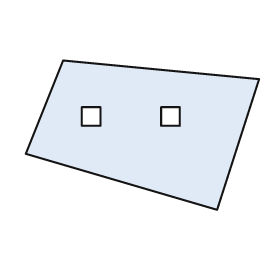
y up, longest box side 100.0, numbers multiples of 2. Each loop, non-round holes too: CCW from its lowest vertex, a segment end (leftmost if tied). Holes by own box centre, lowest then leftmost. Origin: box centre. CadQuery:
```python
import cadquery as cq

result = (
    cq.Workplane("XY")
    .moveTo(32.0, -32.0)
    .lineTo(50.0, 24.0)
    .lineTo(-34.0, 32.0)
    .lineTo(-50.0, -8.0)
    .close()
    .moveTo(-26.0, 4.0)
    .lineTo(-18.0, 4.0)
    .lineTo(-18.0, 12.0)
    .lineTo(-26.0, 12.0)
    .close()
    .moveTo(8.0, 4.0)
    .lineTo(16.0, 4.0)
    .lineTo(16.0, 12.0)
    .lineTo(8.0, 12.0)
    .close()
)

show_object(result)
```